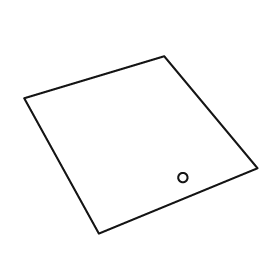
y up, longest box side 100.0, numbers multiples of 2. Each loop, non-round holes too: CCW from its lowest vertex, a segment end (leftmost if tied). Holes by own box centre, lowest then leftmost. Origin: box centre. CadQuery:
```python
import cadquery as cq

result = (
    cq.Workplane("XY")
    .moveTo(-18.0, -38.0)
    .lineTo(50.0, -10.0)
    .lineTo(10.0, 38.0)
    .lineTo(-50.0, 20.0)
    .close()
    .moveTo(18.0, -14.0)
    .circle(2.0)
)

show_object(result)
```